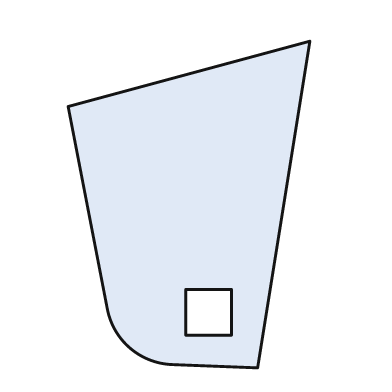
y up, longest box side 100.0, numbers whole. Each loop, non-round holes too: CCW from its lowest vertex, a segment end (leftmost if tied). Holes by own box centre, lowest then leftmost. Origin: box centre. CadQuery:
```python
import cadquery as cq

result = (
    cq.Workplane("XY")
    .moveTo(21.0, -50.0)
    .lineTo(37.0, 50.0)
    .lineTo(-37.0, 30.0)
    .lineTo(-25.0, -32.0)
    .threePointArc((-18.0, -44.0), (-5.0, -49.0))
    .close()
    .moveTo(-1.0, -40.0)
    .lineTo(13.0, -40.0)
    .lineTo(13.0, -26.0)
    .lineTo(-1.0, -26.0)
    .close()
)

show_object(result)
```